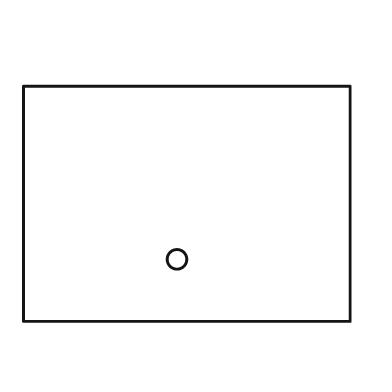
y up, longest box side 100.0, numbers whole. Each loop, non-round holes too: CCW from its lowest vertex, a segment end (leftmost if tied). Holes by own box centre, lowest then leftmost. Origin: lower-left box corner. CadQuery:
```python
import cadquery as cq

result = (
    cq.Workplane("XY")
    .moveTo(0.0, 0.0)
    .lineTo(100.0, 0.0)
    .lineTo(100.0, 72.0)
    .lineTo(0.0, 72.0)
    .close()
    .moveTo(47.0, 19.0)
    .circle(3.0)
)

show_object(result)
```